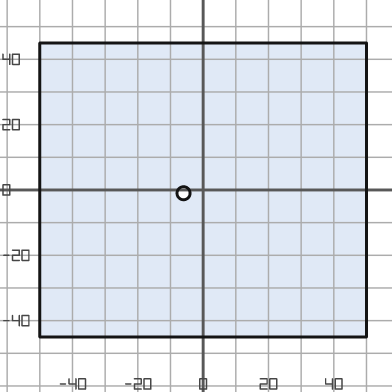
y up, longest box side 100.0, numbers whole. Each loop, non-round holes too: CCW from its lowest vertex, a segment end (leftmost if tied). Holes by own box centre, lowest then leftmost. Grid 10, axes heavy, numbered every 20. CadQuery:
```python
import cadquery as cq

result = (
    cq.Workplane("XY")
    .moveTo(-50.0, -45.0)
    .lineTo(50.0, -45.0)
    .lineTo(50.0, 45.0)
    .lineTo(-50.0, 45.0)
    .close()
    .moveTo(-6.0, -1.0)
    .circle(2.0)
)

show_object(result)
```